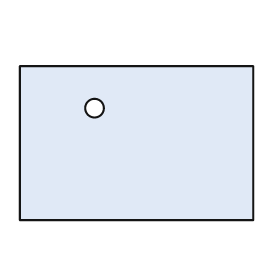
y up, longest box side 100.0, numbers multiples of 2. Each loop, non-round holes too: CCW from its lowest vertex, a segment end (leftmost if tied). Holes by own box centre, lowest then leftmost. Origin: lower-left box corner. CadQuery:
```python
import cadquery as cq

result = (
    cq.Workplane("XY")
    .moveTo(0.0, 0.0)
    .lineTo(100.0, 0.0)
    .lineTo(100.0, 66.0)
    .lineTo(0.0, 66.0)
    .close()
    .moveTo(32.0, 48.0)
    .circle(4.0)
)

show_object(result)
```